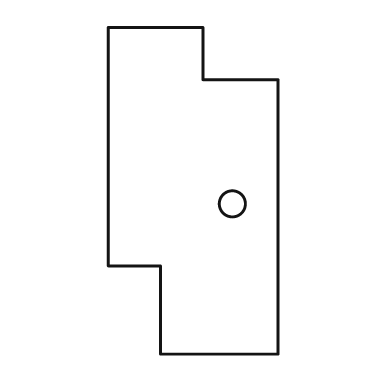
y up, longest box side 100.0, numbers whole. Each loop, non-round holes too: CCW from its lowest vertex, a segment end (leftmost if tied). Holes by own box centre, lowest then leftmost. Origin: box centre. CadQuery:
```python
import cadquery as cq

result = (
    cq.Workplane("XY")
    .moveTo(-10.0, -50.0)
    .lineTo(26.0, -50.0)
    .lineTo(26.0, 34.0)
    .lineTo(3.0, 34.0)
    .lineTo(3.0, 50.0)
    .lineTo(-26.0, 50.0)
    .lineTo(-26.0, -23.0)
    .lineTo(-10.0, -23.0)
    .close()
    .moveTo(12.0, -4.0)
    .circle(4.0)
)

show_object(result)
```